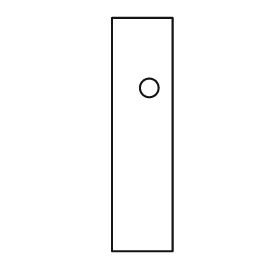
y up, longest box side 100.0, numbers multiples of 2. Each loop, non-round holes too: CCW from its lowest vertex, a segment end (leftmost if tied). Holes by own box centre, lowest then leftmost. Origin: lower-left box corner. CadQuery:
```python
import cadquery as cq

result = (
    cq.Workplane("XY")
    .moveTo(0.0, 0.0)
    .lineTo(26.0, 0.0)
    .lineTo(26.0, 100.0)
    .lineTo(0.0, 100.0)
    .close()
    .moveTo(16.0, 70.0)
    .circle(4.0)
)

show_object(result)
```